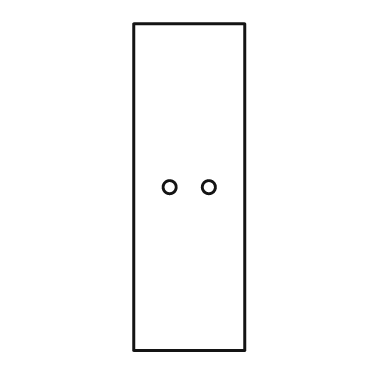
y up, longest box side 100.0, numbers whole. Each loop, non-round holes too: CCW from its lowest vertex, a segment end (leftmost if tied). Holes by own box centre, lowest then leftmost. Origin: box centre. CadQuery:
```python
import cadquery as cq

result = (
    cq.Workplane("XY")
    .moveTo(-17.0, -50.0)
    .lineTo(17.0, -50.0)
    .lineTo(17.0, 50.0)
    .lineTo(-17.0, 50.0)
    .close()
    .moveTo(-6.0, 0.0)
    .circle(2.0)
    .moveTo(6.0, 0.0)
    .circle(2.0)
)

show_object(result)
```